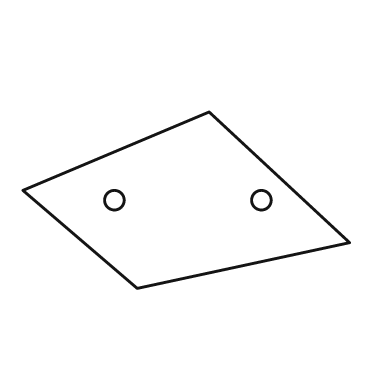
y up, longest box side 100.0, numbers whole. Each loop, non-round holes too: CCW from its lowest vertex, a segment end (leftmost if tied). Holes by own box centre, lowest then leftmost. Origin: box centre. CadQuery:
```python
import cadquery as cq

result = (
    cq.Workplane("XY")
    .moveTo(-15.0, -27.0)
    .lineTo(50.0, -13.0)
    .lineTo(7.0, 27.0)
    .lineTo(-50.0, 3.0)
    .close()
    .moveTo(-22.0, 0.0)
    .circle(3.0)
    .moveTo(23.0, 0.0)
    .circle(3.0)
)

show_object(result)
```